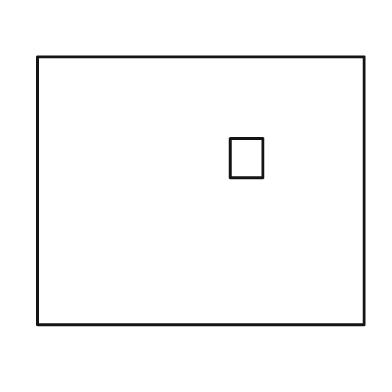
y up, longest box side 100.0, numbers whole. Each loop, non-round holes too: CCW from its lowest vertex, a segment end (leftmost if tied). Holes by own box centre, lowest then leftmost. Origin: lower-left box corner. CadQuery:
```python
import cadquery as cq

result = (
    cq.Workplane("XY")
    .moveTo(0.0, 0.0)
    .lineTo(100.0, 0.0)
    .lineTo(100.0, 82.0)
    .lineTo(0.0, 82.0)
    .close()
    .moveTo(59.0, 45.0)
    .lineTo(69.0, 45.0)
    .lineTo(69.0, 57.0)
    .lineTo(59.0, 57.0)
    .close()
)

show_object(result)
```